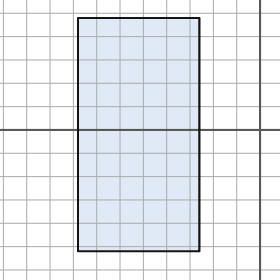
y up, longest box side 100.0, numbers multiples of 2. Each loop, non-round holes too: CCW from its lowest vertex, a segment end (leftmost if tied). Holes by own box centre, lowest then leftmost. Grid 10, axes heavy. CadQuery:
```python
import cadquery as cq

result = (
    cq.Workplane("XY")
    .moveTo(-78.0, -52.0)
    .lineTo(-26.0, -52.0)
    .lineTo(-26.0, 48.0)
    .lineTo(-78.0, 48.0)
    .close()
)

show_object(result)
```